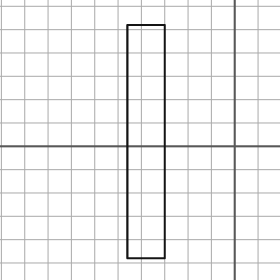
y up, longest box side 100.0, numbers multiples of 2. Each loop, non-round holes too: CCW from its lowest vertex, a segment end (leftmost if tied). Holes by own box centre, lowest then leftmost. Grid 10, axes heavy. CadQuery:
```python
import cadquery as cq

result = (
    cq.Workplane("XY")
    .moveTo(-46.0, -48.0)
    .lineTo(-30.0, -48.0)
    .lineTo(-30.0, 52.0)
    .lineTo(-46.0, 52.0)
    .close()
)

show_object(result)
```